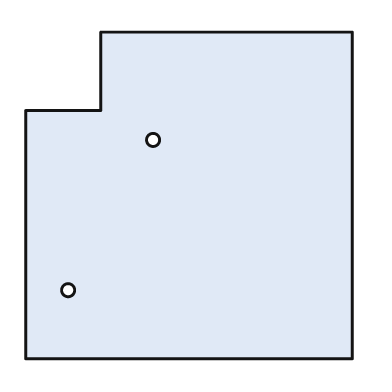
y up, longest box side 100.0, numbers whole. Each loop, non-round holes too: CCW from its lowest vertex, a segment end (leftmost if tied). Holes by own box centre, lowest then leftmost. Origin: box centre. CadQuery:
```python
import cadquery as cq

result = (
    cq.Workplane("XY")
    .moveTo(-50.0, -50.0)
    .lineTo(50.0, -50.0)
    .lineTo(50.0, 50.0)
    .lineTo(-27.0, 50.0)
    .lineTo(-27.0, 26.0)
    .lineTo(-50.0, 26.0)
    .close()
    .moveTo(-37.0, -29.0)
    .circle(2.0)
    .moveTo(-11.0, 17.0)
    .circle(2.0)
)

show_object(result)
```